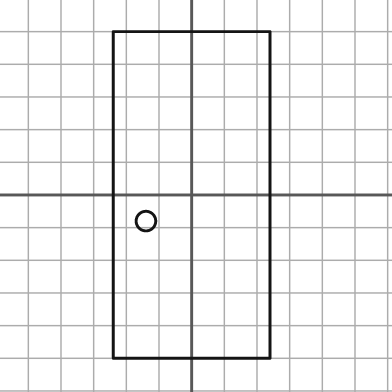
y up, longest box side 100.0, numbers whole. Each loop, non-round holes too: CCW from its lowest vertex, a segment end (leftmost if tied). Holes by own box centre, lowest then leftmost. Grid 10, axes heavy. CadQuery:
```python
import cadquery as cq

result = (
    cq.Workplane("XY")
    .moveTo(-24.0, -50.0)
    .lineTo(24.0, -50.0)
    .lineTo(24.0, 50.0)
    .lineTo(-24.0, 50.0)
    .close()
    .moveTo(-14.0, -8.0)
    .circle(3.0)
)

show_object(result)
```